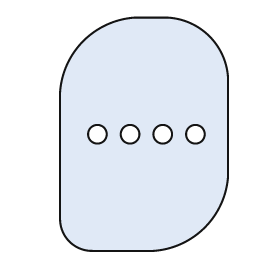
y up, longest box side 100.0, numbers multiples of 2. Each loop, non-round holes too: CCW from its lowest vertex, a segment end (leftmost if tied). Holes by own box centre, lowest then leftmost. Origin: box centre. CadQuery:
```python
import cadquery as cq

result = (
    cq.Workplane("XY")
    .moveTo(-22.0, -50.0)
    .lineTo(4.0, -50.0)
    .threePointArc((26.0, -40.0), (36.0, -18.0))
    .lineTo(36.0, 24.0)
    .threePointArc((28.0, 42.0), (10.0, 50.0))
    .lineTo(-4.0, 50.0)
    .threePointArc((-26.0, 40.0), (-36.0, 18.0))
    .lineTo(-36.0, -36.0)
    .threePointArc((-32.0, -46.0), (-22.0, -50.0))
    .close()
    .moveTo(-20.0, 0.0)
    .circle(4.0)
    .moveTo(-6.0, 0.0)
    .circle(4.0)
    .moveTo(8.0, 0.0)
    .circle(4.0)
    .moveTo(22.0, 0.0)
    .circle(4.0)
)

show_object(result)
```